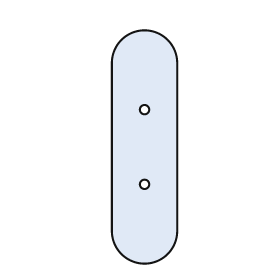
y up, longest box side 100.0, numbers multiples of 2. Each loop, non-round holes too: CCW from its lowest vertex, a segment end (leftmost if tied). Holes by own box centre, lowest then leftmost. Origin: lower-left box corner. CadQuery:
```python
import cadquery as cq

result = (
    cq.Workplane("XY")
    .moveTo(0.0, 14.0)
    .threePointArc((14.0, 0.0), (28.0, 14.0))
    .lineTo(28.0, 86.0)
    .threePointArc((14.0, 100.0), (0.0, 86.0))
    .close()
    .moveTo(14.0, 34.0)
    .circle(2.0)
    .moveTo(14.0, 66.0)
    .circle(2.0)
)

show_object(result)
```